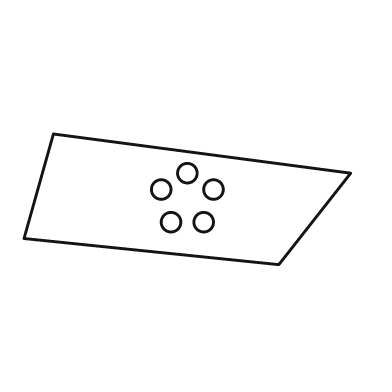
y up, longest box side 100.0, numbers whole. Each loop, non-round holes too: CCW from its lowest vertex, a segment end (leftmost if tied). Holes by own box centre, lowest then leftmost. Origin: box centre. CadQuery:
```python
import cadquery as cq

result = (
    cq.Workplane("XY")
    .moveTo(28.0, -20.0)
    .lineTo(50.0, 8.0)
    .lineTo(-41.0, 20.0)
    .lineTo(-50.0, -12.0)
    .close()
    .moveTo(-5.0, -7.0)
    .circle(3.0)
    .moveTo(5.0, -7.0)
    .circle(3.0)
    .moveTo(-8.0, 3.0)
    .circle(3.0)
    .moveTo(8.0, 3.0)
    .circle(3.0)
    .moveTo(0.0, 8.0)
    .circle(3.0)
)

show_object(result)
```